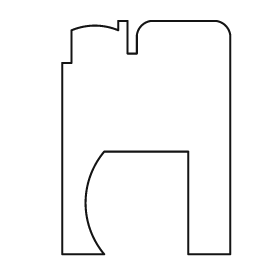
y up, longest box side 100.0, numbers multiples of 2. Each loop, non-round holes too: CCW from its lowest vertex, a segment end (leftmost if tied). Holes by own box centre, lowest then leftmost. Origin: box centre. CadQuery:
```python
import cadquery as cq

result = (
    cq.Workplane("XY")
    .moveTo(-36.0, -50.0)
    .lineTo(-18.0, -50.0)
    .threePointArc((-26.0, -28.0), (-18.0, -6.0))
    .lineTo(18.0, -6.0)
    .lineTo(18.0, -50.0)
    .lineTo(36.0, -50.0)
    .lineTo(36.0, 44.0)
    .threePointArc((34.0, 48.0), (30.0, 50.0))
    .lineTo(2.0, 50.0)
    .threePointArc((-2.0, 48.0), (-4.0, 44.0))
    .lineTo(-4.0, 36.0)
    .lineTo(-8.0, 36.0)
    .lineTo(-8.0, 50.0)
    .lineTo(-12.0, 50.0)
    .lineTo(-12.0, 46.0)
    .threePointArc((-22.0, 48.0), (-32.0, 46.0))
    .lineTo(-32.0, 32.0)
    .lineTo(-36.0, 32.0)
    .close()
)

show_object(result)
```